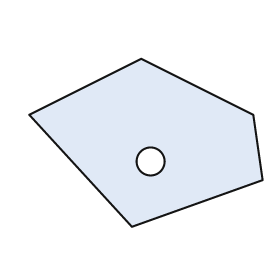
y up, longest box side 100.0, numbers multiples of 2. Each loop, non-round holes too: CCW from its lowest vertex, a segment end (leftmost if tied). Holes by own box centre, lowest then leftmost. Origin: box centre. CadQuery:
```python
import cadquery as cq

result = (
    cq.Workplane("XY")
    .moveTo(-6.0, -36.0)
    .lineTo(50.0, -16.0)
    .lineTo(46.0, 12.0)
    .lineTo(-2.0, 36.0)
    .lineTo(-50.0, 12.0)
    .close()
    .moveTo(2.0, -8.0)
    .circle(6.0)
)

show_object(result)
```